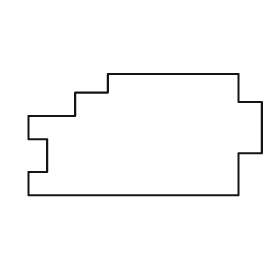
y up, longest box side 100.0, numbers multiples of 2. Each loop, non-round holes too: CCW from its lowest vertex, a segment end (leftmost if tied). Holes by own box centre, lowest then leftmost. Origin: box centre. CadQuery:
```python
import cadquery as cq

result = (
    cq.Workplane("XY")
    .moveTo(-50.0, -26.0)
    .lineTo(40.0, -26.0)
    .lineTo(40.0, -8.0)
    .lineTo(50.0, -8.0)
    .lineTo(50.0, 14.0)
    .lineTo(40.0, 14.0)
    .lineTo(40.0, 26.0)
    .lineTo(-16.0, 26.0)
    .lineTo(-16.0, 18.0)
    .lineTo(-30.0, 18.0)
    .lineTo(-30.0, 8.0)
    .lineTo(-50.0, 8.0)
    .lineTo(-50.0, -2.0)
    .lineTo(-42.0, -2.0)
    .lineTo(-42.0, -16.0)
    .lineTo(-50.0, -16.0)
    .close()
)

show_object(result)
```